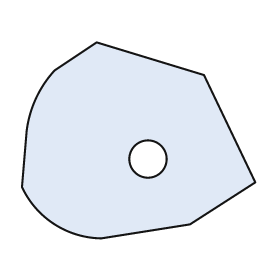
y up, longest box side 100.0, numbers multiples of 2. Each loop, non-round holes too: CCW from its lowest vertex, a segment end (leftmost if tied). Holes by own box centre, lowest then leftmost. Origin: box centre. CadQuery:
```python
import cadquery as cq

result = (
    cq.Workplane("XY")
    .moveTo(-16.0, -42.0)
    .lineTo(22.0, -36.0)
    .lineTo(50.0, -18.0)
    .lineTo(28.0, 28.0)
    .lineTo(-18.0, 42.0)
    .lineTo(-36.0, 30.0)
    .threePointArc((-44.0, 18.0), (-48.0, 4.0))
    .lineTo(-50.0, -20.0)
    .threePointArc((-36.0, -36.0), (-16.0, -42.0))
    .close()
    .moveTo(4.0, -8.0)
    .circle(8.0)
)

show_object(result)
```